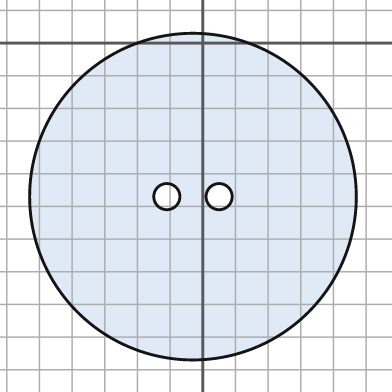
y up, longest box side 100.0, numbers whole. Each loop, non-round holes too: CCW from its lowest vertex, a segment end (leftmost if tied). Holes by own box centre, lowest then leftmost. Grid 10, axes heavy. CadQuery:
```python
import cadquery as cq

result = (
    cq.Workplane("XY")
    .moveTo(-3.0, -47.0)
    .circle(50.0)
    .moveTo(-11.0, -47.0)
    .circle(4.0)
    .moveTo(5.0, -47.0)
    .circle(4.0)
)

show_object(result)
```